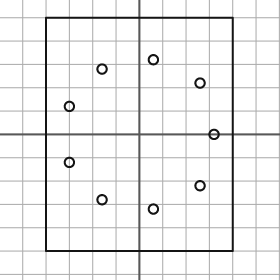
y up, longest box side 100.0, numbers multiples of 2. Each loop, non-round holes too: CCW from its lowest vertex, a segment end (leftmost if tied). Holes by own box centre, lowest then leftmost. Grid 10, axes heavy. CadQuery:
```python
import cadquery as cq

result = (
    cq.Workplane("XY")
    .moveTo(-40.0, -50.0)
    .lineTo(40.0, -50.0)
    .lineTo(40.0, 50.0)
    .lineTo(-40.0, 50.0)
    .close()
    .moveTo(6.0, -32.0)
    .circle(2.0)
    .moveTo(-16.0, -28.0)
    .circle(2.0)
    .moveTo(26.0, -22.0)
    .circle(2.0)
    .moveTo(-30.0, -12.0)
    .circle(2.0)
    .moveTo(32.0, 0.0)
    .circle(2.0)
    .moveTo(-30.0, 12.0)
    .circle(2.0)
    .moveTo(26.0, 22.0)
    .circle(2.0)
    .moveTo(-16.0, 28.0)
    .circle(2.0)
    .moveTo(6.0, 32.0)
    .circle(2.0)
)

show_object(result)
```